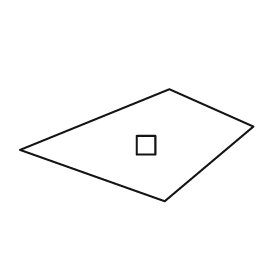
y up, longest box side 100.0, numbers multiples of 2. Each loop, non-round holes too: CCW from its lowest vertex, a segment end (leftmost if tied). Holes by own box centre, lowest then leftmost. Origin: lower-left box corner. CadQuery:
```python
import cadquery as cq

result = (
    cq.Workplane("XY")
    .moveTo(62.0, 0.0)
    .lineTo(100.0, 32.0)
    .lineTo(64.0, 48.0)
    .lineTo(0.0, 22.0)
    .close()
    .moveTo(50.0, 20.0)
    .lineTo(58.0, 20.0)
    .lineTo(58.0, 28.0)
    .lineTo(50.0, 28.0)
    .close()
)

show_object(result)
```